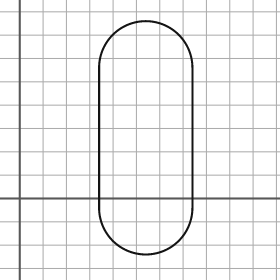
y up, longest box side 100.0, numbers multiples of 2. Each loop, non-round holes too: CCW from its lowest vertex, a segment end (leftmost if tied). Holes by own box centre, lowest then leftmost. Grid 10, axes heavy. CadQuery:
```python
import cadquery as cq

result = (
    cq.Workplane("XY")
    .moveTo(34.0, -4.0)
    .threePointArc((54.0, -24.0), (74.0, -4.0))
    .lineTo(74.0, 56.0)
    .threePointArc((54.0, 76.0), (34.0, 56.0))
    .close()
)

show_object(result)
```